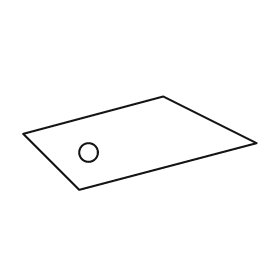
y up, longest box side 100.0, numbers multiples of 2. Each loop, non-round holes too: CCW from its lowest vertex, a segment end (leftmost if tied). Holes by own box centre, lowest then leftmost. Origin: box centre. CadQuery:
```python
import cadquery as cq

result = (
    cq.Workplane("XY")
    .moveTo(-26.0, -20.0)
    .lineTo(50.0, 0.0)
    .lineTo(10.0, 20.0)
    .lineTo(-50.0, 4.0)
    .close()
    .moveTo(-22.0, -4.0)
    .circle(4.0)
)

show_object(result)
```